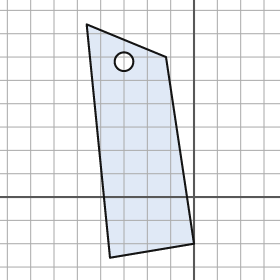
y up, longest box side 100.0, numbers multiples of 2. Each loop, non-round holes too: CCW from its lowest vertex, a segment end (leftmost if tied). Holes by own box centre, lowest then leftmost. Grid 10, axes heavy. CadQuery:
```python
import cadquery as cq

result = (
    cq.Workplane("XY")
    .moveTo(-36.0, -26.0)
    .lineTo(0.0, -20.0)
    .lineTo(-12.0, 60.0)
    .lineTo(-46.0, 74.0)
    .close()
    .moveTo(-30.0, 58.0)
    .circle(4.0)
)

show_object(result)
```